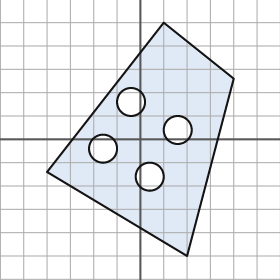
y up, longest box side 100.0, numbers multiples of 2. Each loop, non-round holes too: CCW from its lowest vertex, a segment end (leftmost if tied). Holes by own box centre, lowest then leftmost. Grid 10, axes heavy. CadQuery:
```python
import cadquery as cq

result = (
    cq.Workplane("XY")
    .moveTo(20.0, -50.0)
    .lineTo(40.0, 26.0)
    .lineTo(10.0, 50.0)
    .lineTo(-40.0, -14.0)
    .close()
    .moveTo(4.0, -16.0)
    .circle(6.0)
    .moveTo(-16.0, -4.0)
    .circle(6.0)
    .moveTo(16.0, 4.0)
    .circle(6.0)
    .moveTo(-4.0, 16.0)
    .circle(6.0)
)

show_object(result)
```